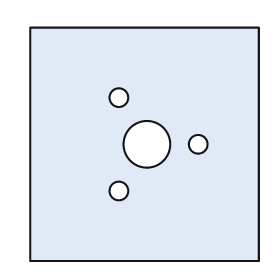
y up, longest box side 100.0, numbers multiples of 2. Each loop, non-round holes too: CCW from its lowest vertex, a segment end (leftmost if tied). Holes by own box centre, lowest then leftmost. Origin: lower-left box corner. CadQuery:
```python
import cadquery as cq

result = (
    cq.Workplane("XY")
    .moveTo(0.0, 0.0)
    .lineTo(98.0, 0.0)
    .lineTo(98.0, 100.0)
    .lineTo(0.0, 100.0)
    .close()
    .moveTo(38.0, 30.0)
    .circle(4.0)
    .moveTo(50.0, 50.0)
    .circle(10.0)
    .moveTo(72.0, 50.0)
    .circle(4.0)
    .moveTo(38.0, 70.0)
    .circle(4.0)
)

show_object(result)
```